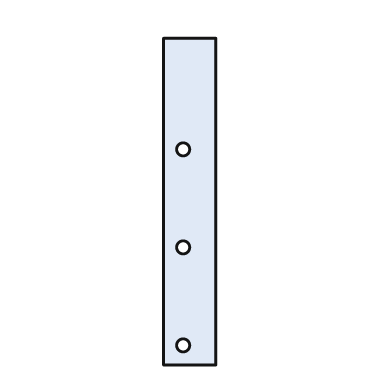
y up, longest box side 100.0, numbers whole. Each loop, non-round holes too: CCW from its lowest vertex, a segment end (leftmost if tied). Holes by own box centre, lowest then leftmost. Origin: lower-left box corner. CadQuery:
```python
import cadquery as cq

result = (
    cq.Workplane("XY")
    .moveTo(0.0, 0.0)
    .lineTo(16.0, 0.0)
    .lineTo(16.0, 100.0)
    .lineTo(0.0, 100.0)
    .close()
    .moveTo(6.0, 6.0)
    .circle(2.0)
    .moveTo(6.0, 36.0)
    .circle(2.0)
    .moveTo(6.0, 66.0)
    .circle(2.0)
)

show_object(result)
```